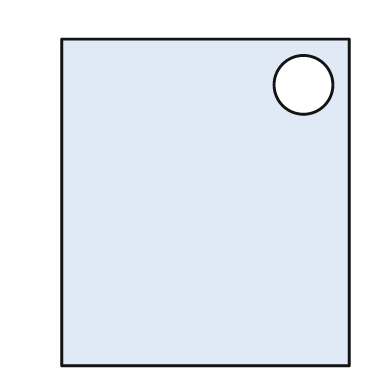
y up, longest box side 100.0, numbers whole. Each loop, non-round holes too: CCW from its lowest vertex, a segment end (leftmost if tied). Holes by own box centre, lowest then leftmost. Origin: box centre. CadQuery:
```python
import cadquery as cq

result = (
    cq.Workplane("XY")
    .moveTo(-44.0, -50.0)
    .lineTo(44.0, -50.0)
    .lineTo(44.0, 50.0)
    .lineTo(-44.0, 50.0)
    .close()
    .moveTo(30.0, 36.0)
    .circle(9.0)
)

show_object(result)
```